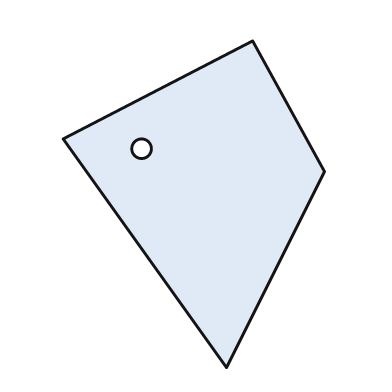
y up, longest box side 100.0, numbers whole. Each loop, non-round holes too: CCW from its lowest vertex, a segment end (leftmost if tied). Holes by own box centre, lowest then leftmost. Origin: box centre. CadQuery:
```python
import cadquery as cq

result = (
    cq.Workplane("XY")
    .moveTo(10.0, -50.0)
    .lineTo(40.0, 10.0)
    .lineTo(18.0, 50.0)
    .lineTo(-40.0, 20.0)
    .close()
    .moveTo(-16.0, 17.0)
    .circle(3.0)
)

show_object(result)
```